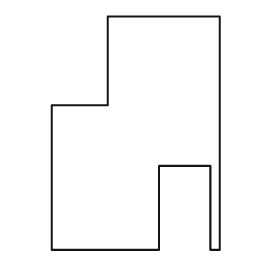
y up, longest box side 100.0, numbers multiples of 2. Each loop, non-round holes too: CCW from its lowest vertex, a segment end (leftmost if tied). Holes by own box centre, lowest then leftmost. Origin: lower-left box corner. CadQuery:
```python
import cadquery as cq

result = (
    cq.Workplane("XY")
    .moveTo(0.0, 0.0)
    .lineTo(46.0, 0.0)
    .lineTo(46.0, 36.0)
    .lineTo(68.0, 36.0)
    .lineTo(68.0, 0.0)
    .lineTo(72.0, 0.0)
    .lineTo(72.0, 100.0)
    .lineTo(24.0, 100.0)
    .lineTo(24.0, 62.0)
    .lineTo(0.0, 62.0)
    .close()
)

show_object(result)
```